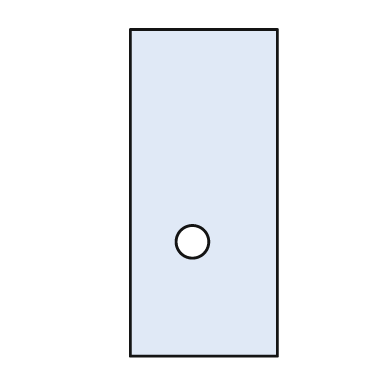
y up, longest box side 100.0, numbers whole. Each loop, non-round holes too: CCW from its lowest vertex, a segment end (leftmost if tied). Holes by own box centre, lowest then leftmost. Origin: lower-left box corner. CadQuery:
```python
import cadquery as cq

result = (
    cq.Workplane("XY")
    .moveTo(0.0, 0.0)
    .lineTo(45.0, 0.0)
    .lineTo(45.0, 100.0)
    .lineTo(0.0, 100.0)
    .close()
    .moveTo(19.0, 35.0)
    .circle(5.0)
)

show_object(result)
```